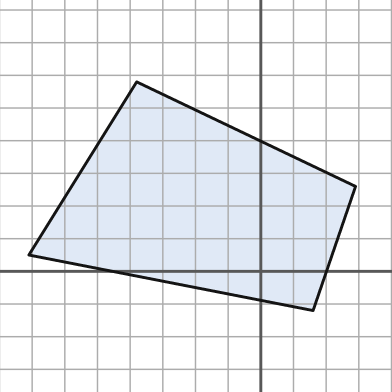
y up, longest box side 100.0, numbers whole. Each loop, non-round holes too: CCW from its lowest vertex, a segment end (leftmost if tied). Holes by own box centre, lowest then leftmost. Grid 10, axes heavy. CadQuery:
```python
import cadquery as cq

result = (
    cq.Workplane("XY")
    .moveTo(16.0, -12.0)
    .lineTo(29.0, 26.0)
    .lineTo(-38.0, 58.0)
    .lineTo(-71.0, 5.0)
    .close()
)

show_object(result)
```